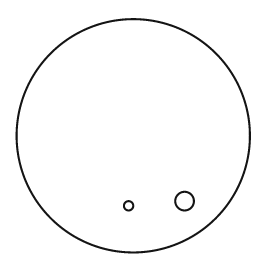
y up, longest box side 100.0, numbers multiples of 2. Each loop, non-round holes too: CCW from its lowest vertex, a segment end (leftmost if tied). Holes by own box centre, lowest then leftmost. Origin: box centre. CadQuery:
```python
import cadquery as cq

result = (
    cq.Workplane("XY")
    .moveTo(0.0, 0.0)
    .circle(50.0)
    .moveTo(-2.0, -30.0)
    .circle(2.0)
    .moveTo(22.0, -28.0)
    .circle(4.0)
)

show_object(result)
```